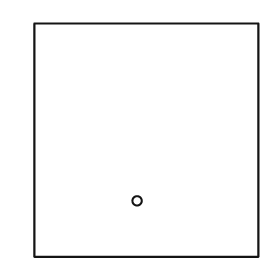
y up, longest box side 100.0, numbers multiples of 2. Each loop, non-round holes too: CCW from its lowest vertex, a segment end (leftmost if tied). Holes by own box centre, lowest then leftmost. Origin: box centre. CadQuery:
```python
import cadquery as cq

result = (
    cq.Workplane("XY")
    .moveTo(-48.0, -50.0)
    .lineTo(48.0, -50.0)
    .lineTo(48.0, 50.0)
    .lineTo(-48.0, 50.0)
    .close()
    .moveTo(-4.0, -26.0)
    .circle(2.0)
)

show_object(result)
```